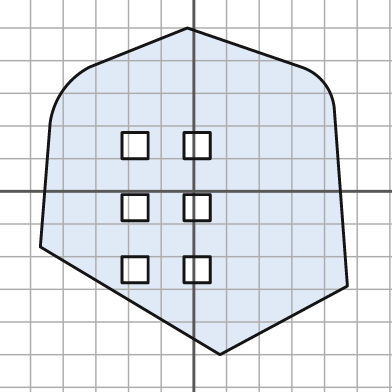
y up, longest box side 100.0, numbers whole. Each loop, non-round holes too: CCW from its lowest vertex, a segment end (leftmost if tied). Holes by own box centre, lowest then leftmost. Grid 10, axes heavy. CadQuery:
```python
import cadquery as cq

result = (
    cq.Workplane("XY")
    .moveTo(8.0, -50.0)
    .lineTo(47.0, -29.0)
    .lineTo(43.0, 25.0)
    .threePointArc((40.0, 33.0), (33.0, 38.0))
    .lineTo(-2.0, 50.0)
    .lineTo(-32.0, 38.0)
    .threePointArc((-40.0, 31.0), (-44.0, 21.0))
    .lineTo(-47.0, -17.0)
    .close()
    .moveTo(-22.0, -28.0)
    .lineTo(-14.0, -28.0)
    .lineTo(-14.0, -20.0)
    .lineTo(-22.0, -20.0)
    .close()
    .moveTo(-3.0, -28.0)
    .lineTo(5.0, -28.0)
    .lineTo(5.0, -20.0)
    .lineTo(-3.0, -20.0)
    .close()
    .moveTo(-22.0, -9.0)
    .lineTo(-14.0, -9.0)
    .lineTo(-14.0, -1.0)
    .lineTo(-22.0, -1.0)
    .close()
    .moveTo(-3.0, -9.0)
    .lineTo(5.0, -9.0)
    .lineTo(5.0, -1.0)
    .lineTo(-3.0, -1.0)
    .close()
    .moveTo(-22.0, 10.0)
    .lineTo(-14.0, 10.0)
    .lineTo(-14.0, 18.0)
    .lineTo(-22.0, 18.0)
    .close()
    .moveTo(-3.0, 10.0)
    .lineTo(5.0, 10.0)
    .lineTo(5.0, 18.0)
    .lineTo(-3.0, 18.0)
    .close()
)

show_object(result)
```